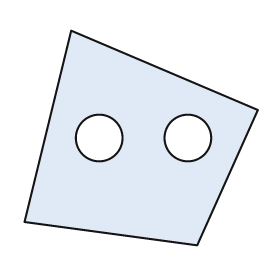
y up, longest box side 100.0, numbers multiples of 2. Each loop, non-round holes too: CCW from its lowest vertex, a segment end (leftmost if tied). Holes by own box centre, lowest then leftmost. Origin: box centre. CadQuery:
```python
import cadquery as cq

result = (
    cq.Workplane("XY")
    .moveTo(24.0, -46.0)
    .lineTo(50.0, 12.0)
    .lineTo(-30.0, 46.0)
    .lineTo(-50.0, -36.0)
    .close()
    .moveTo(-18.0, 0.0)
    .circle(10.0)
    .moveTo(20.0, 0.0)
    .circle(10.0)
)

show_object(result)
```